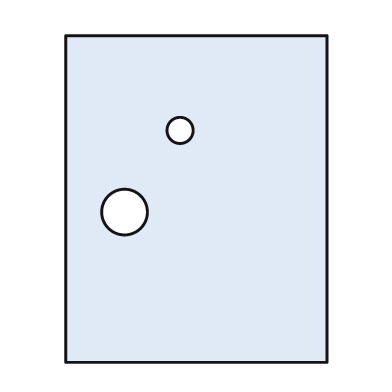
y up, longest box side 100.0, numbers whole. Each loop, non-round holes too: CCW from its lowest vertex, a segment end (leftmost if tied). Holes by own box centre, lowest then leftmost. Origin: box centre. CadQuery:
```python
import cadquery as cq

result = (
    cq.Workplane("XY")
    .moveTo(-40.0, -50.0)
    .lineTo(40.0, -50.0)
    .lineTo(40.0, 50.0)
    .lineTo(-40.0, 50.0)
    .close()
    .moveTo(-22.0, -4.0)
    .circle(7.0)
    .moveTo(-5.0, 21.0)
    .circle(4.0)
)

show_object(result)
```